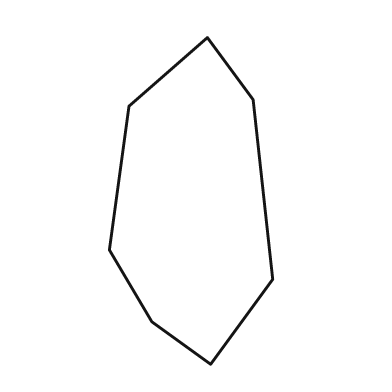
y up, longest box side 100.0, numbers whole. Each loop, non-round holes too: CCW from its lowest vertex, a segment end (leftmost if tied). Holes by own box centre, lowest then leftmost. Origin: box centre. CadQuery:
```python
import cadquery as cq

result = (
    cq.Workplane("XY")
    .moveTo(6.0, -50.0)
    .lineTo(25.0, -24.0)
    .lineTo(19.0, 31.0)
    .lineTo(5.0, 50.0)
    .lineTo(-19.0, 29.0)
    .lineTo(-25.0, -15.0)
    .lineTo(-12.0, -37.0)
    .close()
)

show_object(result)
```